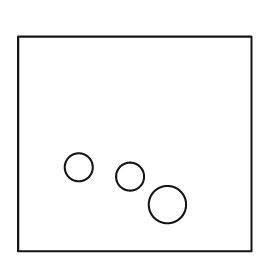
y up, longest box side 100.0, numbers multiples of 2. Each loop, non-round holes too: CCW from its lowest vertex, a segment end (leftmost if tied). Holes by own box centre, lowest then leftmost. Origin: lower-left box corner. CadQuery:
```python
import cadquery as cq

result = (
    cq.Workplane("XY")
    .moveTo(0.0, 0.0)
    .lineTo(100.0, 0.0)
    .lineTo(100.0, 92.0)
    .lineTo(0.0, 92.0)
    .close()
    .moveTo(64.0, 20.0)
    .circle(8.0)
    .moveTo(48.0, 32.0)
    .circle(6.0)
    .moveTo(26.0, 36.0)
    .circle(6.0)
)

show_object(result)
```